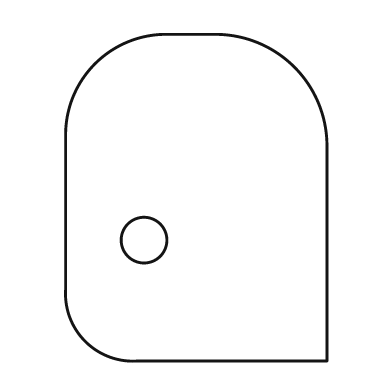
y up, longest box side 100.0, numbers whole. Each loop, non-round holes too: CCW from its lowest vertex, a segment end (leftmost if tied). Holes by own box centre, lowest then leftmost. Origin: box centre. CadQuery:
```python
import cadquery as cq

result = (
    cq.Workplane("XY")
    .moveTo(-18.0, -50.0)
    .lineTo(40.0, -50.0)
    .lineTo(40.0, 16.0)
    .threePointArc((30.0, 40.0), (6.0, 50.0))
    .lineTo(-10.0, 50.0)
    .threePointArc((-31.0, 41.0), (-40.0, 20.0))
    .lineTo(-40.0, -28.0)
    .threePointArc((-34.0, -44.0), (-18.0, -50.0))
    .close()
    .moveTo(-16.0, -13.0)
    .circle(7.0)
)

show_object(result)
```